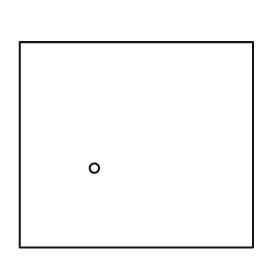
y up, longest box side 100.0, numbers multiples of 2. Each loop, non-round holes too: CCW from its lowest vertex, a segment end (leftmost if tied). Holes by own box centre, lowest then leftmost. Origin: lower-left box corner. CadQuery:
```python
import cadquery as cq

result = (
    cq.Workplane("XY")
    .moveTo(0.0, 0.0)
    .lineTo(100.0, 0.0)
    .lineTo(100.0, 88.0)
    .lineTo(0.0, 88.0)
    .close()
    .moveTo(32.0, 34.0)
    .circle(2.0)
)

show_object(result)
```